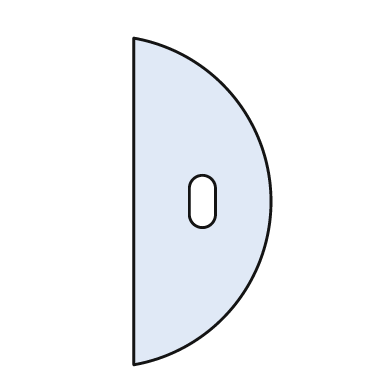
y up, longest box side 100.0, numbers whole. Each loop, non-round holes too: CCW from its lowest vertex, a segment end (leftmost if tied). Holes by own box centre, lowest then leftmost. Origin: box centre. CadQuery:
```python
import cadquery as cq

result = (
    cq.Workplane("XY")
    .moveTo(-21.0, -50.0)
    .threePointArc((21.0, 0.0), (-21.0, 50.0))
    .close()
    .moveTo(-4.0, -4.0)
    .threePointArc((0.0, -8.0), (4.0, -4.0))
    .lineTo(4.0, 4.0)
    .threePointArc((0.0, 8.0), (-4.0, 4.0))
    .close()
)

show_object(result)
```